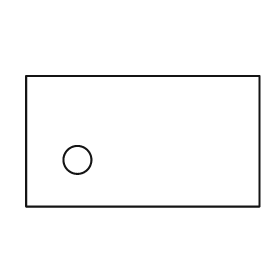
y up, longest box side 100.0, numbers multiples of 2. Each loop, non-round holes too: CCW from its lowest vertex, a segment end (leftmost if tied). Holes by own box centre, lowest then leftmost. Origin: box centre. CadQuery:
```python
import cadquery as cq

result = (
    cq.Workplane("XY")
    .moveTo(-50.0, -28.0)
    .lineTo(50.0, -28.0)
    .lineTo(50.0, 28.0)
    .lineTo(-50.0, 28.0)
    .close()
    .moveTo(-28.0, -8.0)
    .circle(6.0)
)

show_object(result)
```